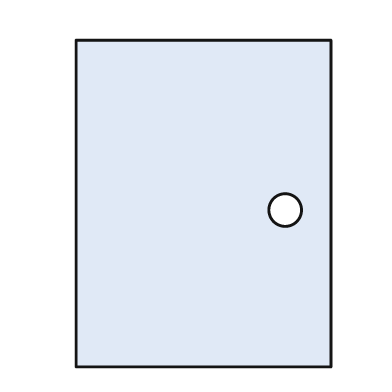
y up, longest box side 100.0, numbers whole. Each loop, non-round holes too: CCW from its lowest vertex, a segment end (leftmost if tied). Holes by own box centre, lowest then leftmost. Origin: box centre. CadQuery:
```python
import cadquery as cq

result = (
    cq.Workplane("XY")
    .moveTo(-39.0, -50.0)
    .lineTo(39.0, -50.0)
    .lineTo(39.0, 50.0)
    .lineTo(-39.0, 50.0)
    .close()
    .moveTo(25.0, -2.0)
    .circle(5.0)
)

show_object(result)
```